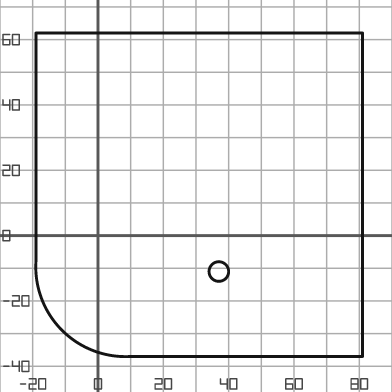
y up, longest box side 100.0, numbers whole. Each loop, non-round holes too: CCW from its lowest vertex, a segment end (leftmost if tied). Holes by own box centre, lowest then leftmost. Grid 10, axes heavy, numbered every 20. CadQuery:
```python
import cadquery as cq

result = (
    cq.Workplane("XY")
    .moveTo(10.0, -37.0)
    .lineTo(81.0, -37.0)
    .lineTo(81.0, 62.0)
    .lineTo(-19.0, 62.0)
    .lineTo(-19.0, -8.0)
    .threePointArc((-11.0, -29.0), (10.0, -37.0))
    .close()
    .moveTo(37.0, -11.0)
    .circle(3.0)
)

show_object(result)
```